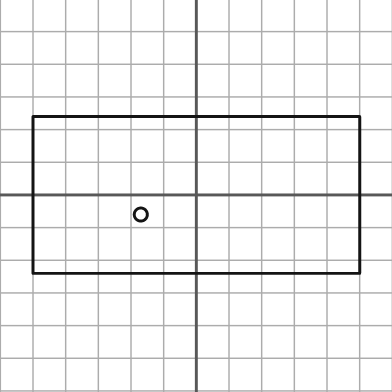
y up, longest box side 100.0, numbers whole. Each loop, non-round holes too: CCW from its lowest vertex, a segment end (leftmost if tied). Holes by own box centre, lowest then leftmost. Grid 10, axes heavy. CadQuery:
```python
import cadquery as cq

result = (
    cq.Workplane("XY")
    .moveTo(-50.0, -24.0)
    .lineTo(50.0, -24.0)
    .lineTo(50.0, 24.0)
    .lineTo(-50.0, 24.0)
    .close()
    .moveTo(-17.0, -6.0)
    .circle(2.0)
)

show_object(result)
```